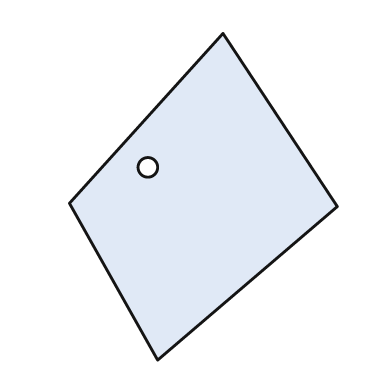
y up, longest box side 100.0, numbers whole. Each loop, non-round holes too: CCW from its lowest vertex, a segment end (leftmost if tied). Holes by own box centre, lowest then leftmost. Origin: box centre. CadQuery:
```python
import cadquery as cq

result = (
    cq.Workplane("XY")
    .moveTo(-14.0, -50.0)
    .lineTo(41.0, -3.0)
    .lineTo(6.0, 50.0)
    .lineTo(-41.0, -2.0)
    .close()
    .moveTo(-17.0, 9.0)
    .circle(3.0)
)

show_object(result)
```